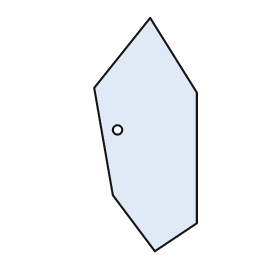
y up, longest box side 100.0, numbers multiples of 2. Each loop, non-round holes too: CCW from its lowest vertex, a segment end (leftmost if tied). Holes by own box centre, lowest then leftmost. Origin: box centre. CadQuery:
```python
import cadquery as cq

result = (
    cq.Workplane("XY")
    .moveTo(4.0, -50.0)
    .lineTo(22.0, -38.0)
    .lineTo(22.0, 18.0)
    .lineTo(2.0, 50.0)
    .lineTo(-22.0, 20.0)
    .lineTo(-14.0, -26.0)
    .close()
    .moveTo(-12.0, 2.0)
    .circle(2.0)
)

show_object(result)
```